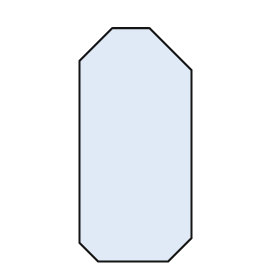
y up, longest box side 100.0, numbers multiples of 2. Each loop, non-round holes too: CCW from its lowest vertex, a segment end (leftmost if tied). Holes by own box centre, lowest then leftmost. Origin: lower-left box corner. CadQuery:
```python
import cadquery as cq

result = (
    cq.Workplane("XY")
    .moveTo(8.0, 0.0)
    .lineTo(38.0, 0.0)
    .lineTo(48.0, 10.0)
    .lineTo(48.0, 82.0)
    .lineTo(30.0, 100.0)
    .lineTo(14.0, 100.0)
    .lineTo(0.0, 86.0)
    .lineTo(0.0, 8.0)
    .close()
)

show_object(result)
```